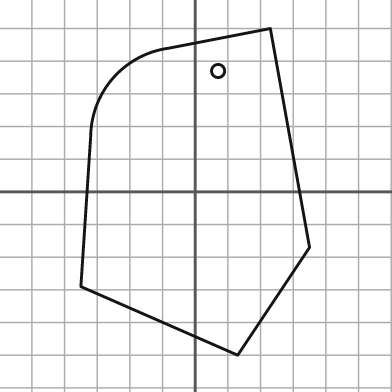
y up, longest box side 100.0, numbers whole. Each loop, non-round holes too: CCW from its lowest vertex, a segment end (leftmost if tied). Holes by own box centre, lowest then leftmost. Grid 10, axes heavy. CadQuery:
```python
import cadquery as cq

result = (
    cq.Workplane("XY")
    .moveTo(13.0, -50.0)
    .lineTo(35.0, -17.0)
    .lineTo(23.0, 50.0)
    .lineTo(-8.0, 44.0)
    .threePointArc((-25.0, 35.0), (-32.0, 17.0))
    .lineTo(-35.0, -29.0)
    .close()
    .moveTo(7.0, 37.0)
    .circle(2.0)
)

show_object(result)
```